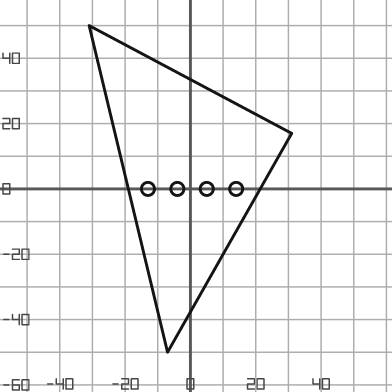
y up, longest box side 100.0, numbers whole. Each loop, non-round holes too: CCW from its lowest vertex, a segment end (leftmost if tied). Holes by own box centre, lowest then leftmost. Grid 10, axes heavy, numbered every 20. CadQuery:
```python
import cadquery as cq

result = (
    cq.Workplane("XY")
    .moveTo(-7.0, -50.0)
    .lineTo(31.0, 17.0)
    .lineTo(-31.0, 50.0)
    .close()
    .moveTo(-13.0, 0.0)
    .circle(2.0)
    .moveTo(-4.0, 0.0)
    .circle(2.0)
    .moveTo(5.0, 0.0)
    .circle(2.0)
    .moveTo(14.0, 0.0)
    .circle(2.0)
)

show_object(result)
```